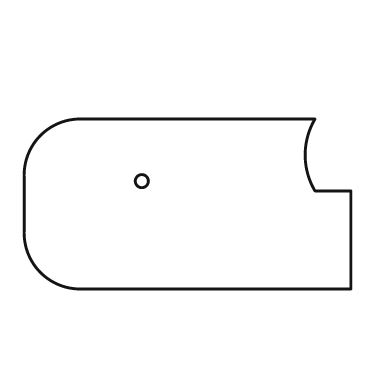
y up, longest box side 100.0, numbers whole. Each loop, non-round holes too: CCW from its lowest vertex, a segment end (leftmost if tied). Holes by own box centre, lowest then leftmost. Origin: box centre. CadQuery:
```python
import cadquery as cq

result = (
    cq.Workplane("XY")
    .moveTo(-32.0, -26.0)
    .lineTo(50.0, -26.0)
    .lineTo(50.0, 4.0)
    .lineTo(39.0, 4.0)
    .threePointArc((36.0, 15.0), (39.0, 26.0))
    .lineTo(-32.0, 26.0)
    .threePointArc((-45.0, 21.0), (-50.0, 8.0))
    .lineTo(-50.0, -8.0)
    .threePointArc((-45.0, -21.0), (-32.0, -26.0))
    .close()
    .moveTo(-14.0, 7.0)
    .circle(2.0)
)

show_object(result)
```